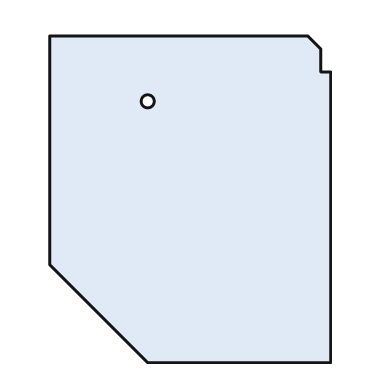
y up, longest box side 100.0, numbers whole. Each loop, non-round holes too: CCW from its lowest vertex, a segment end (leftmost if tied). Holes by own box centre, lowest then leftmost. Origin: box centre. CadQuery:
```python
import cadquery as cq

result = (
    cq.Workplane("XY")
    .moveTo(-13.0, -50.0)
    .lineTo(43.0, -50.0)
    .lineTo(43.0, 39.0)
    .lineTo(40.0, 39.0)
    .lineTo(40.0, 46.0)
    .lineTo(36.0, 50.0)
    .lineTo(-43.0, 50.0)
    .lineTo(-43.0, -20.0)
    .close()
    .moveTo(-13.0, 30.0)
    .circle(2.0)
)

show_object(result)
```